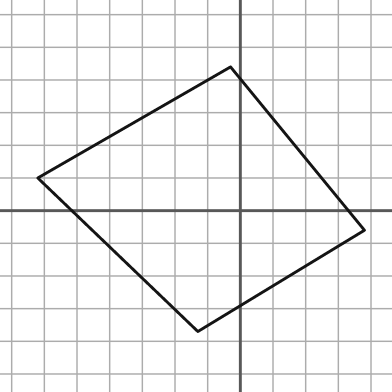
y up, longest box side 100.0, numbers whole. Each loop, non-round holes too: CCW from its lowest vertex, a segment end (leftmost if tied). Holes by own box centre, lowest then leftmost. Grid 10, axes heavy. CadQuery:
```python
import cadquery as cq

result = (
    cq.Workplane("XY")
    .moveTo(-13.0, -37.0)
    .lineTo(38.0, -6.0)
    .lineTo(-3.0, 44.0)
    .lineTo(-62.0, 10.0)
    .close()
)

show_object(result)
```